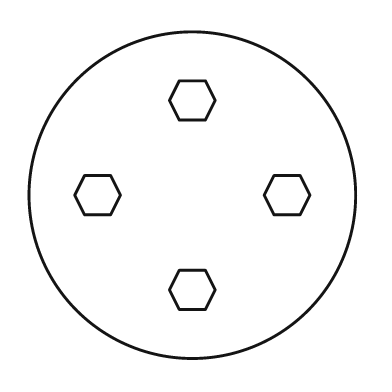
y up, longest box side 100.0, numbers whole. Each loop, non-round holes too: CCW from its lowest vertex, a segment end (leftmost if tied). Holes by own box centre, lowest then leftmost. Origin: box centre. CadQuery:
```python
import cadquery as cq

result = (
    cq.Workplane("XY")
    .moveTo(0.0, 0.0)
    .circle(50.0)
    .moveTo(-4.0, -35.0)
    .lineTo(4.0, -35.0)
    .lineTo(7.0, -29.0)
    .lineTo(4.0, -23.0)
    .lineTo(-4.0, -23.0)
    .lineTo(-7.0, -29.0)
    .close()
    .moveTo(-33.0, -6.0)
    .lineTo(-25.0, -6.0)
    .lineTo(-22.0, 0.0)
    .lineTo(-25.0, 6.0)
    .lineTo(-33.0, 6.0)
    .lineTo(-36.0, 0.0)
    .close()
    .moveTo(25.0, -6.0)
    .lineTo(33.0, -6.0)
    .lineTo(36.0, 0.0)
    .lineTo(33.0, 6.0)
    .lineTo(25.0, 6.0)
    .lineTo(22.0, 0.0)
    .close()
    .moveTo(-4.0, 23.0)
    .lineTo(4.0, 23.0)
    .lineTo(7.0, 29.0)
    .lineTo(4.0, 35.0)
    .lineTo(-4.0, 35.0)
    .lineTo(-7.0, 29.0)
    .close()
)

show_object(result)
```